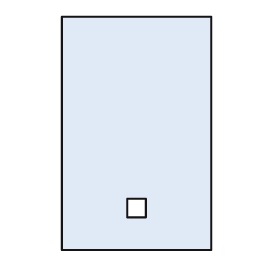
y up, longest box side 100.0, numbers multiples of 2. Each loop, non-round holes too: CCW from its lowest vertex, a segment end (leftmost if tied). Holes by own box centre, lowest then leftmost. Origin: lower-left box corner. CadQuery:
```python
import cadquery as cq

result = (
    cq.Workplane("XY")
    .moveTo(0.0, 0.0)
    .lineTo(64.0, 0.0)
    .lineTo(64.0, 100.0)
    .lineTo(0.0, 100.0)
    .close()
    .moveTo(28.0, 14.0)
    .lineTo(36.0, 14.0)
    .lineTo(36.0, 22.0)
    .lineTo(28.0, 22.0)
    .close()
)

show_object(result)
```